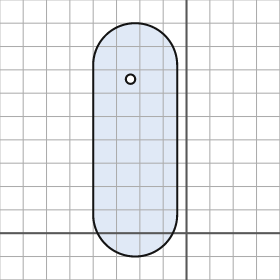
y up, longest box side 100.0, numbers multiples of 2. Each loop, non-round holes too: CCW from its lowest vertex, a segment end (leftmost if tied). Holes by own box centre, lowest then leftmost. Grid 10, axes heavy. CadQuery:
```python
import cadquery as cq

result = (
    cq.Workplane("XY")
    .moveTo(-40.0, 8.0)
    .threePointArc((-22.0, -10.0), (-4.0, 8.0))
    .lineTo(-4.0, 72.0)
    .threePointArc((-22.0, 90.0), (-40.0, 72.0))
    .close()
    .moveTo(-24.0, 66.0)
    .circle(2.0)
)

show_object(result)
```